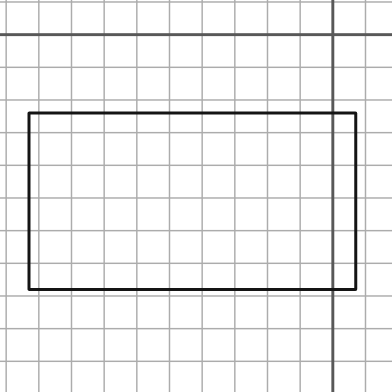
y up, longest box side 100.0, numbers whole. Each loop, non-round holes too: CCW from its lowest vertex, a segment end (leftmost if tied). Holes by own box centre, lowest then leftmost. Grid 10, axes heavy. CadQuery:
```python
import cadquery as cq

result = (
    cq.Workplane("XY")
    .moveTo(-93.0, -78.0)
    .lineTo(7.0, -78.0)
    .lineTo(7.0, -24.0)
    .lineTo(-93.0, -24.0)
    .close()
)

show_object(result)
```